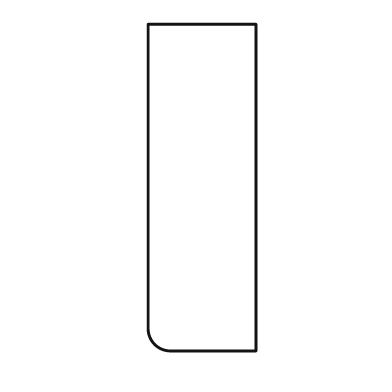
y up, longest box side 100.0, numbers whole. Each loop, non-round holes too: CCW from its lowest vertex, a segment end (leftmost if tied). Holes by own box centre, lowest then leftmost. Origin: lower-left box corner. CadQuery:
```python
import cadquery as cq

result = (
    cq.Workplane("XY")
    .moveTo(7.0, 0.0)
    .lineTo(33.0, 0.0)
    .lineTo(33.0, 100.0)
    .lineTo(0.0, 100.0)
    .lineTo(0.0, 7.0)
    .threePointArc((2.0, 2.0), (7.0, 0.0))
    .close()
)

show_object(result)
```